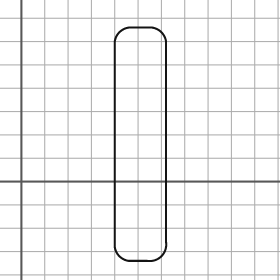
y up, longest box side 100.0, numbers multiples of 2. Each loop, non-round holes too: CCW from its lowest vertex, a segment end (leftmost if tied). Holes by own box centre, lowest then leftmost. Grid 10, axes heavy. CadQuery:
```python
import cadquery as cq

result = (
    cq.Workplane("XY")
    .moveTo(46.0, -34.0)
    .lineTo(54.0, -34.0)
    .threePointArc((60.0, -32.0), (62.0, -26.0))
    .lineTo(62.0, 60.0)
    .threePointArc((60.0, 64.0), (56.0, 66.0))
    .lineTo(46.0, 66.0)
    .threePointArc((42.0, 64.0), (40.0, 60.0))
    .lineTo(40.0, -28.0)
    .threePointArc((42.0, -32.0), (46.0, -34.0))
    .close()
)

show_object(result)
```